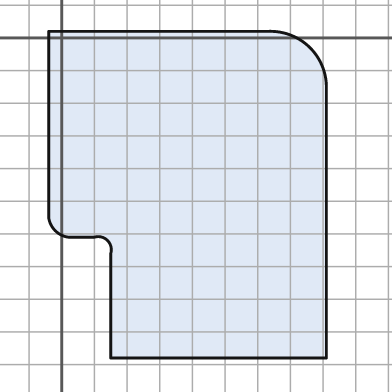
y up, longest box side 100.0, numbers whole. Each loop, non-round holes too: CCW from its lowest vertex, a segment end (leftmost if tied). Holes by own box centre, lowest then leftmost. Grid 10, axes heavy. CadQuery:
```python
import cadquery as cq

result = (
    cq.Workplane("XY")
    .moveTo(15.0, -98.0)
    .lineTo(81.0, -98.0)
    .lineTo(81.0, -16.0)
    .threePointArc((76.0, -3.0), (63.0, 2.0))
    .lineTo(-4.0, 2.0)
    .lineTo(-4.0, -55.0)
    .threePointArc((-2.0, -59.0), (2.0, -61.0))
    .lineTo(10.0, -61.0)
    .threePointArc((14.0, -62.0), (15.0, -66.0))
    .close()
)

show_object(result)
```